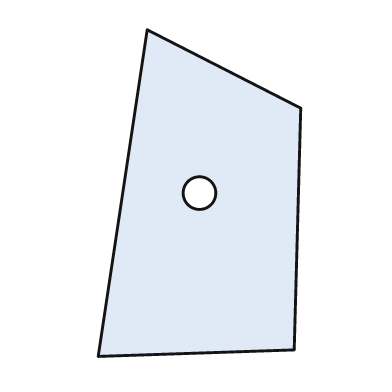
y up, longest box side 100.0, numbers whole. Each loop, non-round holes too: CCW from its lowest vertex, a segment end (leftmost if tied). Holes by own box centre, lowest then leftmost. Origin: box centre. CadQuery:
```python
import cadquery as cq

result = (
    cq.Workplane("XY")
    .moveTo(-31.0, -50.0)
    .lineTo(29.0, -48.0)
    .lineTo(31.0, 26.0)
    .lineTo(-16.0, 50.0)
    .close()
    .moveTo(0.0, 0.0)
    .circle(5.0)
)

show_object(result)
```